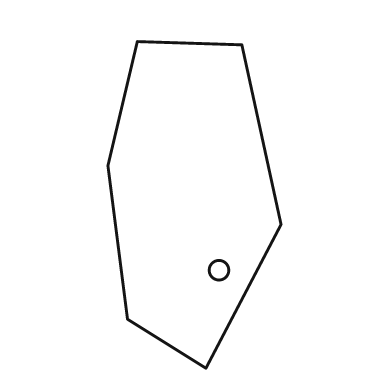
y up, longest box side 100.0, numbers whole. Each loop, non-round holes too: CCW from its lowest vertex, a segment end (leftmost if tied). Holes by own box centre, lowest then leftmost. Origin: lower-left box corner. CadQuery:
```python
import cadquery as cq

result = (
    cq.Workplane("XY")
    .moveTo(30.0, 0.0)
    .lineTo(53.0, 44.0)
    .lineTo(41.0, 99.0)
    .lineTo(9.0, 100.0)
    .lineTo(0.0, 62.0)
    .lineTo(6.0, 15.0)
    .close()
    .moveTo(34.0, 30.0)
    .circle(3.0)
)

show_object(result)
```